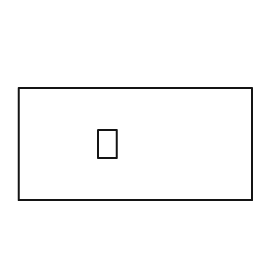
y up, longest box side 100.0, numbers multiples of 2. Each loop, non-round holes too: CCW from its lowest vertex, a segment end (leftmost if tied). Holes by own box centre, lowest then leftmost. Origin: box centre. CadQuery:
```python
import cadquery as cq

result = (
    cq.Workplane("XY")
    .moveTo(-50.0, -24.0)
    .lineTo(50.0, -24.0)
    .lineTo(50.0, 24.0)
    .lineTo(-50.0, 24.0)
    .close()
    .moveTo(-16.0, -6.0)
    .lineTo(-8.0, -6.0)
    .lineTo(-8.0, 6.0)
    .lineTo(-16.0, 6.0)
    .close()
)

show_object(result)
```